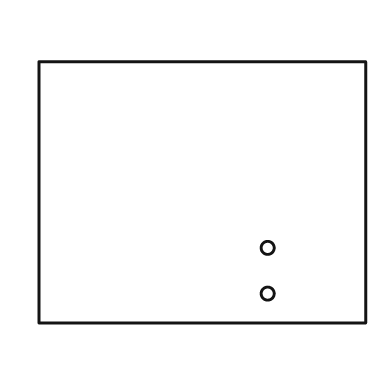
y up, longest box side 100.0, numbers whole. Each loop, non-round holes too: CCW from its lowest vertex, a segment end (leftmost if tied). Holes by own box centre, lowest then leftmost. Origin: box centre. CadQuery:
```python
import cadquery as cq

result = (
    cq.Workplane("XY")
    .moveTo(-50.0, -40.0)
    .lineTo(50.0, -40.0)
    .lineTo(50.0, 40.0)
    .lineTo(-50.0, 40.0)
    .close()
    .moveTo(20.0, -31.0)
    .circle(2.0)
    .moveTo(20.0, -17.0)
    .circle(2.0)
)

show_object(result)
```